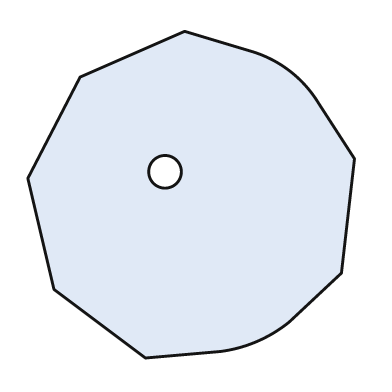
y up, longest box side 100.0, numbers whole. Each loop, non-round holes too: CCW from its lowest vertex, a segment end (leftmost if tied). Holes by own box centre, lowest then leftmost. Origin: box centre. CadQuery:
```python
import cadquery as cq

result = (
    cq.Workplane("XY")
    .moveTo(-14.0, -50.0)
    .lineTo(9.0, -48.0)
    .threePointArc((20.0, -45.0), (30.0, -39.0))
    .lineTo(46.0, -24.0)
    .lineTo(50.0, 11.0)
    .lineTo(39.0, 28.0)
    .threePointArc((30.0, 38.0), (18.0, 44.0))
    .lineTo(-2.0, 50.0)
    .lineTo(-34.0, 36.0)
    .lineTo(-50.0, 5.0)
    .lineTo(-42.0, -29.0)
    .close()
    .moveTo(-8.0, 7.0)
    .circle(5.0)
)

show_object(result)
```